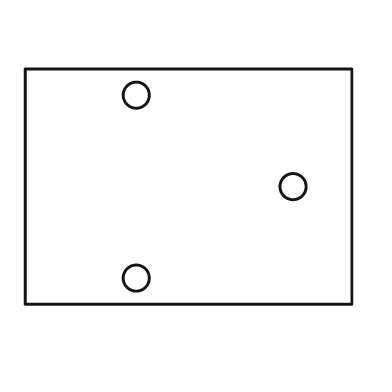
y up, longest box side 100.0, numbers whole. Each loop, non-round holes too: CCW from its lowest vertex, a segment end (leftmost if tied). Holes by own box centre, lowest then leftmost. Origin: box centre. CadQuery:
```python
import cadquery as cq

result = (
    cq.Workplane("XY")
    .moveTo(-50.0, -36.0)
    .lineTo(50.0, -36.0)
    .lineTo(50.0, 36.0)
    .lineTo(-50.0, 36.0)
    .close()
    .moveTo(-16.0, -28.0)
    .circle(4.0)
    .moveTo(32.0, 0.0)
    .circle(4.0)
    .moveTo(-16.0, 28.0)
    .circle(4.0)
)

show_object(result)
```